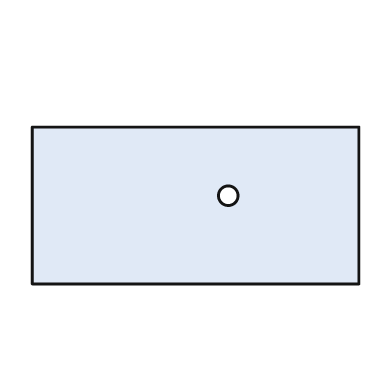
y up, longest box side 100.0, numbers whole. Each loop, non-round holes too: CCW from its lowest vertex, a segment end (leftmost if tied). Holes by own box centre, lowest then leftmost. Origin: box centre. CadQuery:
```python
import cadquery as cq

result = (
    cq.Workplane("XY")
    .moveTo(-50.0, -24.0)
    .lineTo(50.0, -24.0)
    .lineTo(50.0, 24.0)
    .lineTo(-50.0, 24.0)
    .close()
    .moveTo(10.0, 3.0)
    .circle(3.0)
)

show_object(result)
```